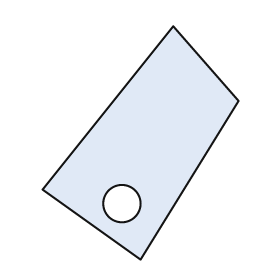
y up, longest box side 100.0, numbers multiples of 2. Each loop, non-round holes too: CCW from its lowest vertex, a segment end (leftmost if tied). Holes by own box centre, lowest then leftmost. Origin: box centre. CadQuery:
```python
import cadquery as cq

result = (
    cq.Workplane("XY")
    .moveTo(0.0, -50.0)
    .lineTo(42.0, 18.0)
    .lineTo(14.0, 50.0)
    .lineTo(-42.0, -20.0)
    .close()
    .moveTo(-8.0, -26.0)
    .circle(8.0)
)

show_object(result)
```